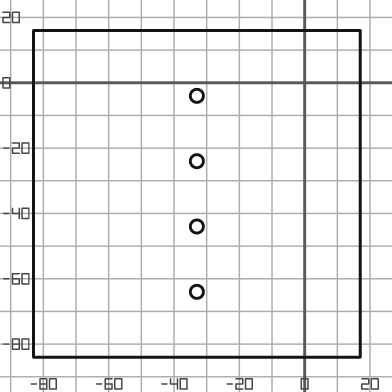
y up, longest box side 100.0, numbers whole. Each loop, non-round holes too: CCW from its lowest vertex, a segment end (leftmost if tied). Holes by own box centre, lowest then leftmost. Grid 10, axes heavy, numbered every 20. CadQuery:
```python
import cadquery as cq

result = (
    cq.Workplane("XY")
    .moveTo(-83.0, -84.0)
    .lineTo(17.0, -84.0)
    .lineTo(17.0, 16.0)
    .lineTo(-83.0, 16.0)
    .close()
    .moveTo(-33.0, -64.0)
    .circle(2.0)
    .moveTo(-33.0, -44.0)
    .circle(2.0)
    .moveTo(-33.0, -24.0)
    .circle(2.0)
    .moveTo(-33.0, -4.0)
    .circle(2.0)
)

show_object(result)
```